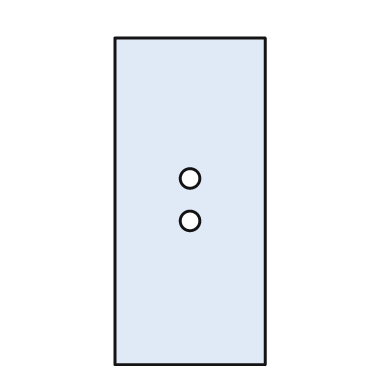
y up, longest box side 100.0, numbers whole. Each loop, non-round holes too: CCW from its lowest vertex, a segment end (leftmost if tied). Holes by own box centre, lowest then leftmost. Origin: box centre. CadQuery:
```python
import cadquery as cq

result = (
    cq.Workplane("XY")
    .moveTo(-23.0, -50.0)
    .lineTo(23.0, -50.0)
    .lineTo(23.0, 50.0)
    .lineTo(-23.0, 50.0)
    .close()
    .moveTo(0.0, -6.0)
    .circle(3.0)
    .moveTo(0.0, 7.0)
    .circle(3.0)
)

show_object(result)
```